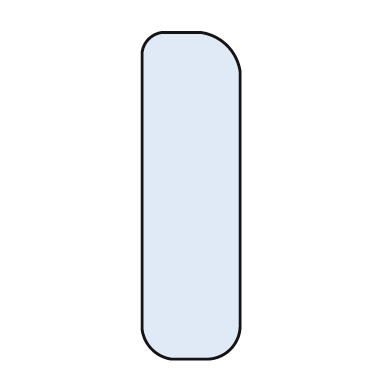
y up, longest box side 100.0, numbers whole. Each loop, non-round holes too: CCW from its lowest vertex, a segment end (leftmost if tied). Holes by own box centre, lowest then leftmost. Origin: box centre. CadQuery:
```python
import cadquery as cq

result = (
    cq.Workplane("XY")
    .moveTo(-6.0, -50.0)
    .lineTo(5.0, -50.0)
    .threePointArc((12.0, -47.0), (15.0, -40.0))
    .lineTo(15.0, 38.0)
    .threePointArc((11.0, 46.0), (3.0, 50.0))
    .lineTo(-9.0, 50.0)
    .threePointArc((-13.0, 48.0), (-15.0, 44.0))
    .lineTo(-15.0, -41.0)
    .threePointArc((-12.0, -47.0), (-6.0, -50.0))
    .close()
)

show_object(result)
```